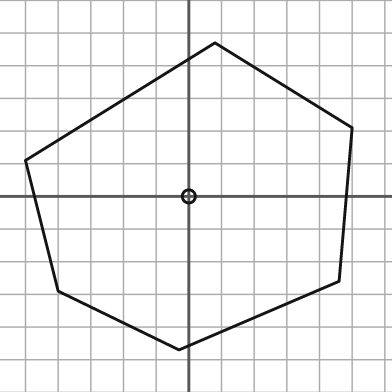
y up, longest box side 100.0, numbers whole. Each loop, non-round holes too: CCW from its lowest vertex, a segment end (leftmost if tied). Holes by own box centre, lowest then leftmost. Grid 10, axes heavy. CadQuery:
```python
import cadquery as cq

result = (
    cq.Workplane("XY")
    .moveTo(-3.0, -47.0)
    .lineTo(46.0, -26.0)
    .lineTo(50.0, 21.0)
    .lineTo(8.0, 47.0)
    .lineTo(-50.0, 11.0)
    .lineTo(-40.0, -29.0)
    .close()
    .moveTo(0.0, 0.0)
    .circle(2.0)
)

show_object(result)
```